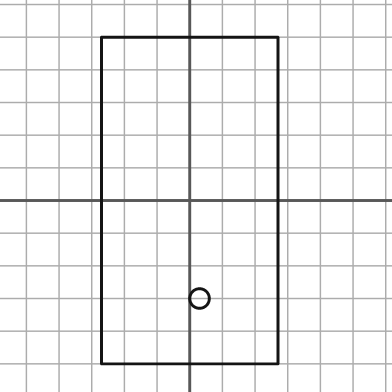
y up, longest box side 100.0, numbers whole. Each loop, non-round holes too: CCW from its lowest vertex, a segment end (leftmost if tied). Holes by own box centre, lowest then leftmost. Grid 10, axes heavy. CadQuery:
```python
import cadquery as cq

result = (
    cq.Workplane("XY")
    .moveTo(-27.0, -50.0)
    .lineTo(27.0, -50.0)
    .lineTo(27.0, 50.0)
    .lineTo(-27.0, 50.0)
    .close()
    .moveTo(3.0, -30.0)
    .circle(3.0)
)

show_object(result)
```